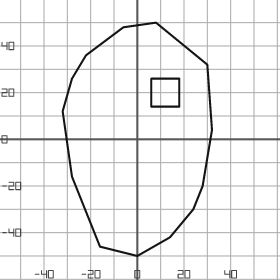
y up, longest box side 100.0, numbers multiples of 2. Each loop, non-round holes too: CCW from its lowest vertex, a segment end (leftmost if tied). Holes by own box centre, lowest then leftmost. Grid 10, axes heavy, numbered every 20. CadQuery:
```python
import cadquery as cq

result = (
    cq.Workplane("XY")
    .moveTo(0.0, -50.0)
    .lineTo(14.0, -42.0)
    .lineTo(24.0, -30.0)
    .lineTo(28.0, -20.0)
    .lineTo(32.0, 4.0)
    .lineTo(30.0, 32.0)
    .lineTo(8.0, 50.0)
    .lineTo(-6.0, 48.0)
    .lineTo(-22.0, 36.0)
    .lineTo(-28.0, 26.0)
    .lineTo(-32.0, 12.0)
    .lineTo(-28.0, -16.0)
    .lineTo(-16.0, -46.0)
    .close()
    .moveTo(6.0, 14.0)
    .lineTo(18.0, 14.0)
    .lineTo(18.0, 26.0)
    .lineTo(6.0, 26.0)
    .close()
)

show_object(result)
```